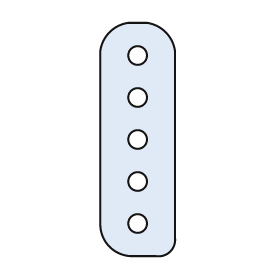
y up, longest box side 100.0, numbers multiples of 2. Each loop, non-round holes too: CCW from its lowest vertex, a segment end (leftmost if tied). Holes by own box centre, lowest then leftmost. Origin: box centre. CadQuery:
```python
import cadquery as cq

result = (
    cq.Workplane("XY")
    .moveTo(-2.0, -50.0)
    .lineTo(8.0, -50.0)
    .threePointArc((14.0, -48.0), (16.0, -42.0))
    .lineTo(16.0, 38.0)
    .threePointArc((12.0, 46.0), (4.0, 50.0))
    .lineTo(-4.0, 50.0)
    .threePointArc((-12.0, 46.0), (-16.0, 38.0))
    .lineTo(-16.0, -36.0)
    .threePointArc((-12.0, -46.0), (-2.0, -50.0))
    .close()
    .moveTo(0.0, -36.0)
    .circle(4.0)
    .moveTo(0.0, -18.0)
    .circle(4.0)
    .moveTo(0.0, 0.0)
    .circle(4.0)
    .moveTo(0.0, 18.0)
    .circle(4.0)
    .moveTo(0.0, 36.0)
    .circle(4.0)
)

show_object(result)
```